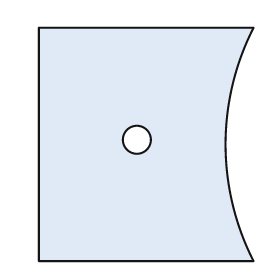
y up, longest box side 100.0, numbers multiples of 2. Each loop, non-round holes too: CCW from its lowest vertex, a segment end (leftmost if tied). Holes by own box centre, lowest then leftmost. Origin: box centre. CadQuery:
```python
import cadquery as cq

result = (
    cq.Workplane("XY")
    .moveTo(-46.0, -50.0)
    .lineTo(46.0, -50.0)
    .threePointArc((34.0, 0.0), (46.0, 50.0))
    .lineTo(-46.0, 50.0)
    .close()
    .moveTo(-4.0, 2.0)
    .circle(6.0)
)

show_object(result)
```